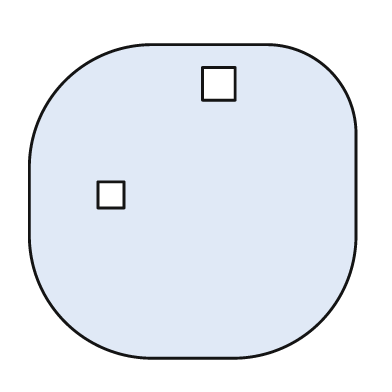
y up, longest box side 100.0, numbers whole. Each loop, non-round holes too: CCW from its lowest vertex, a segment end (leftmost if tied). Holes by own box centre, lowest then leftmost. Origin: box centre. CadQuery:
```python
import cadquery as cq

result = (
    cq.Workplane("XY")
    .moveTo(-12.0, -48.0)
    .lineTo(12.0, -48.0)
    .threePointArc((39.0, -37.0), (50.0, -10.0))
    .lineTo(50.0, 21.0)
    .threePointArc((42.0, 40.0), (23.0, 48.0))
    .lineTo(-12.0, 48.0)
    .threePointArc((-39.0, 37.0), (-50.0, 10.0))
    .lineTo(-50.0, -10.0)
    .threePointArc((-39.0, -37.0), (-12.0, -48.0))
    .close()
    .moveTo(-29.0, -2.0)
    .lineTo(-21.0, -2.0)
    .lineTo(-21.0, 6.0)
    .lineTo(-29.0, 6.0)
    .close()
    .moveTo(3.0, 31.0)
    .lineTo(13.0, 31.0)
    .lineTo(13.0, 41.0)
    .lineTo(3.0, 41.0)
    .close()
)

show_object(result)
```